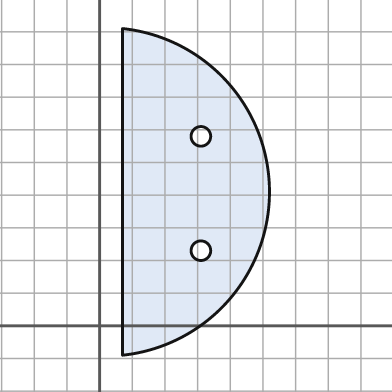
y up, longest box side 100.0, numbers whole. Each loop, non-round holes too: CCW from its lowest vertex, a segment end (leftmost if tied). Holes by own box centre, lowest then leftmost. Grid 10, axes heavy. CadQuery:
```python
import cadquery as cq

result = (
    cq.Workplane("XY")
    .moveTo(7.0, -9.0)
    .threePointArc((52.0, 41.0), (7.0, 91.0))
    .close()
    .moveTo(31.0, 23.0)
    .circle(3.0)
    .moveTo(31.0, 58.0)
    .circle(3.0)
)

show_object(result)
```